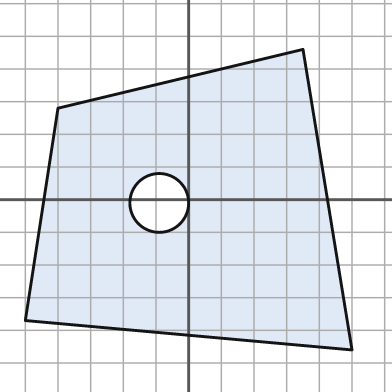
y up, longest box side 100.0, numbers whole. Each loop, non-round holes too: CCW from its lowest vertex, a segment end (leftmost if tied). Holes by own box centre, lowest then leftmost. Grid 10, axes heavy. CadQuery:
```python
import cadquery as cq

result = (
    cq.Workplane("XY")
    .moveTo(50.0, -46.0)
    .lineTo(35.0, 46.0)
    .lineTo(-40.0, 28.0)
    .lineTo(-50.0, -37.0)
    .close()
    .moveTo(-9.0, -1.0)
    .circle(9.0)
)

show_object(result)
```